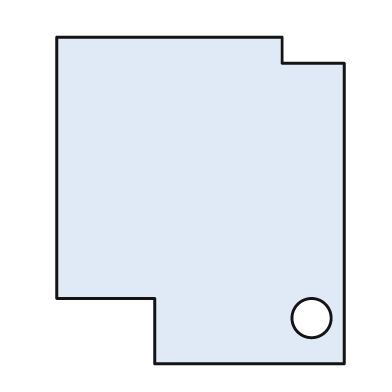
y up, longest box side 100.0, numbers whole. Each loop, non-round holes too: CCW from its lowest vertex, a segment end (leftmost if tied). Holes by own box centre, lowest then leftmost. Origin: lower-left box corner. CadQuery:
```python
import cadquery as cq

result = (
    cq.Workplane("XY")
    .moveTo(30.0, 0.0)
    .lineTo(88.0, 0.0)
    .lineTo(88.0, 92.0)
    .lineTo(69.0, 92.0)
    .lineTo(69.0, 100.0)
    .lineTo(0.0, 100.0)
    .lineTo(0.0, 20.0)
    .lineTo(30.0, 20.0)
    .close()
    .moveTo(78.0, 14.0)
    .circle(6.0)
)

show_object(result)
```